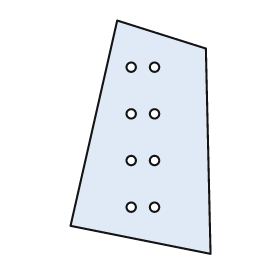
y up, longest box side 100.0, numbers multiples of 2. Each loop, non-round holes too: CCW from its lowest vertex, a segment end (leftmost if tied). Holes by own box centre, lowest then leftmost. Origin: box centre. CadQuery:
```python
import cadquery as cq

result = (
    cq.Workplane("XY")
    .moveTo(30.0, -50.0)
    .lineTo(28.0, 38.0)
    .lineTo(-10.0, 50.0)
    .lineTo(-30.0, -38.0)
    .close()
    .moveTo(-4.0, -30.0)
    .circle(2.0)
    .moveTo(6.0, -30.0)
    .circle(2.0)
    .moveTo(-4.0, -10.0)
    .circle(2.0)
    .moveTo(6.0, -10.0)
    .circle(2.0)
    .moveTo(-4.0, 10.0)
    .circle(2.0)
    .moveTo(6.0, 10.0)
    .circle(2.0)
    .moveTo(-4.0, 30.0)
    .circle(2.0)
    .moveTo(6.0, 30.0)
    .circle(2.0)
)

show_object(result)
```